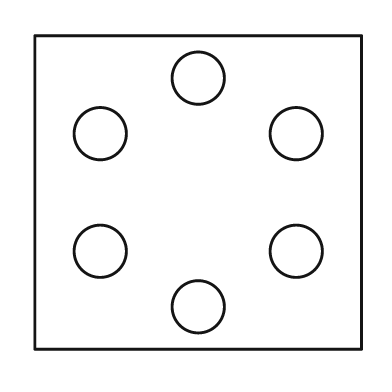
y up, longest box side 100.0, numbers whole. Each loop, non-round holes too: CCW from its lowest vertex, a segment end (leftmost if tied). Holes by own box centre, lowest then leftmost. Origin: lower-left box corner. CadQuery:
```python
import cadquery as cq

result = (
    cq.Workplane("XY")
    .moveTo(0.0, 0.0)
    .lineTo(100.0, 0.0)
    .lineTo(100.0, 96.0)
    .lineTo(0.0, 96.0)
    .close()
    .moveTo(50.0, 13.0)
    .circle(8.0)
    .moveTo(20.0, 30.0)
    .circle(8.0)
    .moveTo(80.0, 30.0)
    .circle(8.0)
    .moveTo(20.0, 66.0)
    .circle(8.0)
    .moveTo(80.0, 66.0)
    .circle(8.0)
    .moveTo(50.0, 83.0)
    .circle(8.0)
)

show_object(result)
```